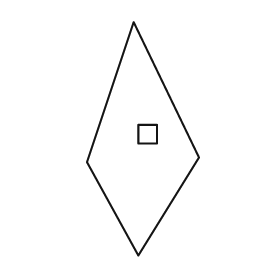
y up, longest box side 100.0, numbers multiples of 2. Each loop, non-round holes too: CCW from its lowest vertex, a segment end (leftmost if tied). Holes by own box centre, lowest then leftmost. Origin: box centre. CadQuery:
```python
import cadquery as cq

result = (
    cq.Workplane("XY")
    .moveTo(-2.0, -50.0)
    .lineTo(24.0, -8.0)
    .lineTo(-4.0, 50.0)
    .lineTo(-24.0, -10.0)
    .close()
    .moveTo(-2.0, -2.0)
    .lineTo(6.0, -2.0)
    .lineTo(6.0, 6.0)
    .lineTo(-2.0, 6.0)
    .close()
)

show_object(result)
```